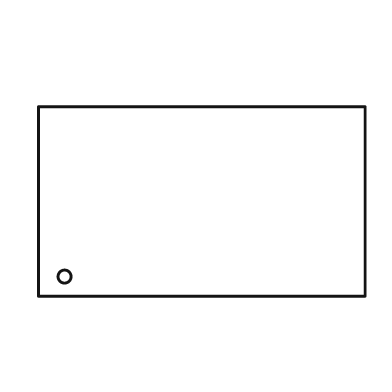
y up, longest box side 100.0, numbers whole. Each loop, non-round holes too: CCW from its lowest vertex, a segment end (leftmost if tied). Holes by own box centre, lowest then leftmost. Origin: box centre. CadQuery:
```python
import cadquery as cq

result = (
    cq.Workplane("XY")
    .moveTo(-50.0, -29.0)
    .lineTo(50.0, -29.0)
    .lineTo(50.0, 29.0)
    .lineTo(-50.0, 29.0)
    .close()
    .moveTo(-42.0, -23.0)
    .circle(2.0)
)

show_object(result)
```